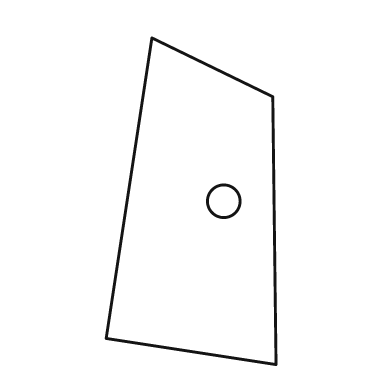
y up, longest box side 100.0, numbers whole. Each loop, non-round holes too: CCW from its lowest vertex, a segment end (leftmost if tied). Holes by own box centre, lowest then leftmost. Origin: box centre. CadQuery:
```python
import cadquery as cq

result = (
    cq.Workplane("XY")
    .moveTo(26.0, -50.0)
    .lineTo(25.0, 32.0)
    .lineTo(-12.0, 50.0)
    .lineTo(-26.0, -42.0)
    .close()
    .moveTo(10.0, 0.0)
    .circle(5.0)
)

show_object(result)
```